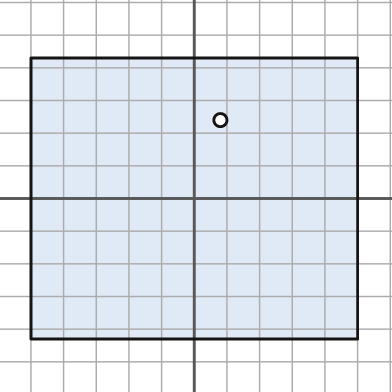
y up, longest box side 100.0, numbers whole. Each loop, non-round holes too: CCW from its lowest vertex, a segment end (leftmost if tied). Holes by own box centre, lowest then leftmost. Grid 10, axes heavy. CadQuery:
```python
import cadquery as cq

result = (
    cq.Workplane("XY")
    .moveTo(-50.0, -43.0)
    .lineTo(50.0, -43.0)
    .lineTo(50.0, 43.0)
    .lineTo(-50.0, 43.0)
    .close()
    .moveTo(8.0, 24.0)
    .circle(2.0)
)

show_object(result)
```